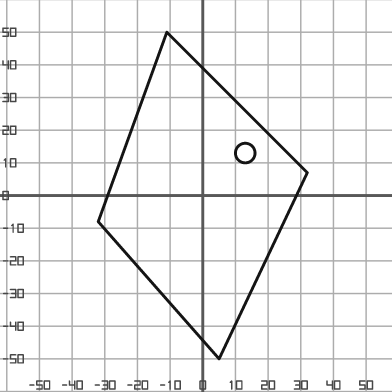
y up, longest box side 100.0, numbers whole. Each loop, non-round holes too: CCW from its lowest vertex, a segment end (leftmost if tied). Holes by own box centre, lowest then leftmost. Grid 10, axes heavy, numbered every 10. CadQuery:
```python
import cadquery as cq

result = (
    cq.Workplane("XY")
    .moveTo(5.0, -50.0)
    .lineTo(32.0, 7.0)
    .lineTo(-11.0, 50.0)
    .lineTo(-32.0, -8.0)
    .close()
    .moveTo(13.0, 13.0)
    .circle(3.0)
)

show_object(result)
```